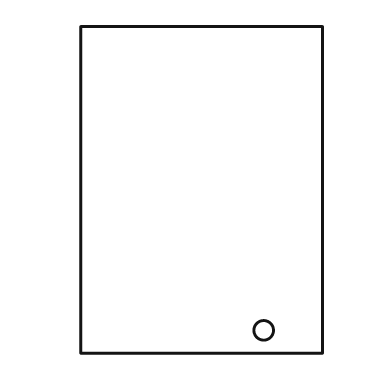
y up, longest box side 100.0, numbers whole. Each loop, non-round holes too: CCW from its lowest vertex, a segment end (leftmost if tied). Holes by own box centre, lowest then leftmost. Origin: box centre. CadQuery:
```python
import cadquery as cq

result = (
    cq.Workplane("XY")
    .moveTo(-37.0, -50.0)
    .lineTo(37.0, -50.0)
    .lineTo(37.0, 50.0)
    .lineTo(-37.0, 50.0)
    .close()
    .moveTo(19.0, -43.0)
    .circle(3.0)
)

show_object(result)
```